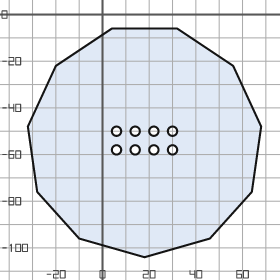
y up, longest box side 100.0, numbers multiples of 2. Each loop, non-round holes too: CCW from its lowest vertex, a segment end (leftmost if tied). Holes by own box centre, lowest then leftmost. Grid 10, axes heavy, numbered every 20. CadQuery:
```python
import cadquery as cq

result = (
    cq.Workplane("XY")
    .moveTo(18.0, -104.0)
    .lineTo(46.0, -96.0)
    .lineTo(64.0, -76.0)
    .lineTo(68.0, -48.0)
    .lineTo(56.0, -22.0)
    .lineTo(32.0, -6.0)
    .lineTo(4.0, -6.0)
    .lineTo(-20.0, -22.0)
    .lineTo(-32.0, -48.0)
    .lineTo(-28.0, -76.0)
    .lineTo(-10.0, -96.0)
    .close()
    .moveTo(6.0, -58.0)
    .circle(2.0)
    .moveTo(14.0, -58.0)
    .circle(2.0)
    .moveTo(22.0, -58.0)
    .circle(2.0)
    .moveTo(30.0, -58.0)
    .circle(2.0)
    .moveTo(6.0, -50.0)
    .circle(2.0)
    .moveTo(14.0, -50.0)
    .circle(2.0)
    .moveTo(22.0, -50.0)
    .circle(2.0)
    .moveTo(30.0, -50.0)
    .circle(2.0)
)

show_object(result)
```